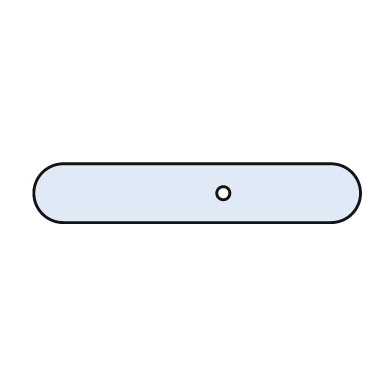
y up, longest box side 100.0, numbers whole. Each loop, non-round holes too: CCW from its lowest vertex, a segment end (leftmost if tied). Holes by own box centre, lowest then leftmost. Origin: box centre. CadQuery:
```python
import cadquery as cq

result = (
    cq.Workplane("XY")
    .moveTo(-41.0, -9.0)
    .lineTo(41.0, -9.0)
    .threePointArc((50.0, 0.0), (41.0, 9.0))
    .lineTo(-41.0, 9.0)
    .threePointArc((-50.0, 0.0), (-41.0, -9.0))
    .close()
    .moveTo(8.0, 0.0)
    .circle(2.0)
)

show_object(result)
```